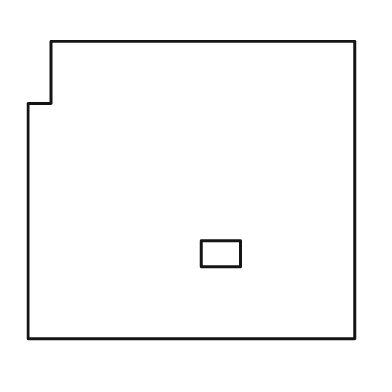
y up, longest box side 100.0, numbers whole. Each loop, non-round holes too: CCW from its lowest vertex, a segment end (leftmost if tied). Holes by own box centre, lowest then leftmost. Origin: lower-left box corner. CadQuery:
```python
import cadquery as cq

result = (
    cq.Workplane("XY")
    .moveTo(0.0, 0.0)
    .lineTo(100.0, 0.0)
    .lineTo(100.0, 91.0)
    .lineTo(7.0, 91.0)
    .lineTo(7.0, 72.0)
    .lineTo(0.0, 72.0)
    .close()
    .moveTo(53.0, 22.0)
    .lineTo(65.0, 22.0)
    .lineTo(65.0, 30.0)
    .lineTo(53.0, 30.0)
    .close()
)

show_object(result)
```